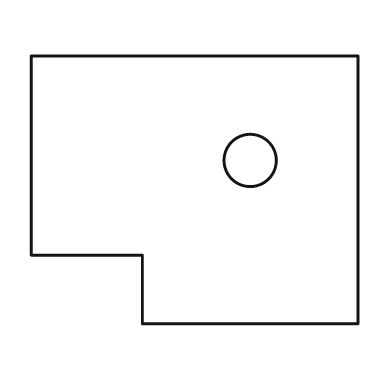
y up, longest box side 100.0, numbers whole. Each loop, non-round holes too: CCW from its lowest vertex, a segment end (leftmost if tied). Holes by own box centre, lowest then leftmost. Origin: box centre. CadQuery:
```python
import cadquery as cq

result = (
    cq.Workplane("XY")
    .moveTo(-16.0, -41.0)
    .lineTo(50.0, -41.0)
    .lineTo(50.0, 41.0)
    .lineTo(-50.0, 41.0)
    .lineTo(-50.0, -20.0)
    .lineTo(-16.0, -20.0)
    .close()
    .moveTo(17.0, 9.0)
    .circle(8.0)
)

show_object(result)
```